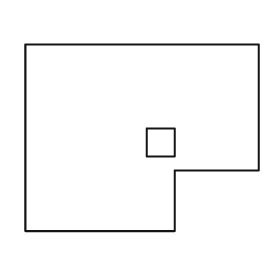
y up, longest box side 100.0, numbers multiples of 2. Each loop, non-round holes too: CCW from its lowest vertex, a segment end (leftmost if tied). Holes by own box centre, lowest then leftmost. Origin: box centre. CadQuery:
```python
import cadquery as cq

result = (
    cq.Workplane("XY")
    .moveTo(-50.0, -40.0)
    .lineTo(14.0, -40.0)
    .lineTo(14.0, -14.0)
    .lineTo(50.0, -14.0)
    .lineTo(50.0, 40.0)
    .lineTo(-50.0, 40.0)
    .close()
    .moveTo(2.0, -8.0)
    .lineTo(14.0, -8.0)
    .lineTo(14.0, 4.0)
    .lineTo(2.0, 4.0)
    .close()
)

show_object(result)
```